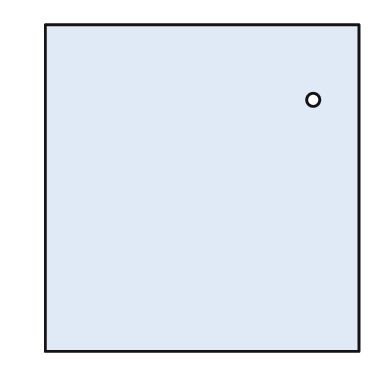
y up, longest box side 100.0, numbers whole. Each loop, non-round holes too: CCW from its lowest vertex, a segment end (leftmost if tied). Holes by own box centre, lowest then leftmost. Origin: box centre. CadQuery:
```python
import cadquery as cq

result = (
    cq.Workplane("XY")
    .moveTo(-48.0, -50.0)
    .lineTo(48.0, -50.0)
    .lineTo(48.0, 50.0)
    .lineTo(-48.0, 50.0)
    .close()
    .moveTo(34.0, 27.0)
    .circle(2.0)
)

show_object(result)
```